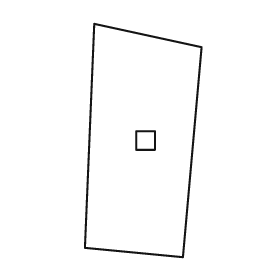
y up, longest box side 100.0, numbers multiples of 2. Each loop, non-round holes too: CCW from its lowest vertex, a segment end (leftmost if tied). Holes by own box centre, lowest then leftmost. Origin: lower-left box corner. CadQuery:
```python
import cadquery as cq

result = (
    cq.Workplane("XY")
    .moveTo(42.0, 0.0)
    .lineTo(50.0, 90.0)
    .lineTo(4.0, 100.0)
    .lineTo(0.0, 4.0)
    .close()
    .moveTo(22.0, 46.0)
    .lineTo(30.0, 46.0)
    .lineTo(30.0, 54.0)
    .lineTo(22.0, 54.0)
    .close()
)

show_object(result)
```